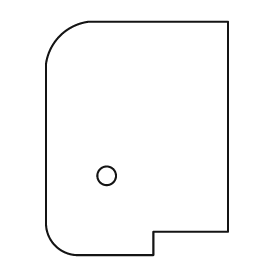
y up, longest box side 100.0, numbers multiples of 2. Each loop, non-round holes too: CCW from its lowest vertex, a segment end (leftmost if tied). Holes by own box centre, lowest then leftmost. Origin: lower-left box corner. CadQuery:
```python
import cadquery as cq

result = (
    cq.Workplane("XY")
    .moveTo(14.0, 0.0)
    .lineTo(46.0, 0.0)
    .lineTo(46.0, 10.0)
    .lineTo(78.0, 10.0)
    .lineTo(78.0, 100.0)
    .lineTo(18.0, 100.0)
    .threePointArc((6.0, 94.0), (0.0, 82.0))
    .lineTo(0.0, 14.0)
    .threePointArc((4.0, 4.0), (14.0, 0.0))
    .close()
    .moveTo(26.0, 34.0)
    .circle(4.0)
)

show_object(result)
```